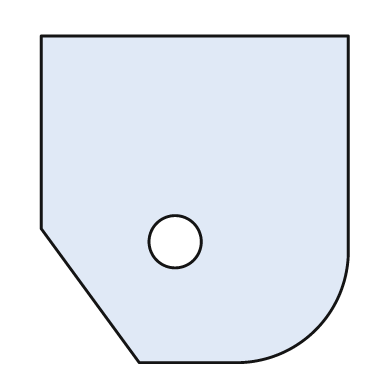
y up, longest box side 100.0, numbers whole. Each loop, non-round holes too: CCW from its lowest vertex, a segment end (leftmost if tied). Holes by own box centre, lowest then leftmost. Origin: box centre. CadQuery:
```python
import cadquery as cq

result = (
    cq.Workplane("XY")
    .moveTo(-17.0, -50.0)
    .lineTo(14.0, -50.0)
    .threePointArc((37.0, -40.0), (47.0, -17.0))
    .lineTo(47.0, 50.0)
    .lineTo(-47.0, 50.0)
    .lineTo(-47.0, -9.0)
    .close()
    .moveTo(-6.0, -13.0)
    .circle(8.0)
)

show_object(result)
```